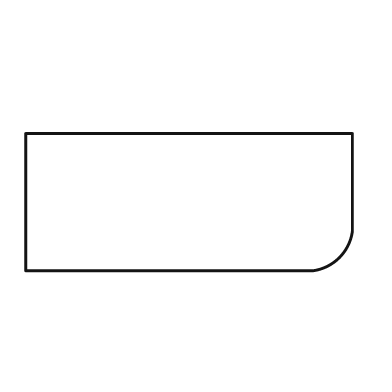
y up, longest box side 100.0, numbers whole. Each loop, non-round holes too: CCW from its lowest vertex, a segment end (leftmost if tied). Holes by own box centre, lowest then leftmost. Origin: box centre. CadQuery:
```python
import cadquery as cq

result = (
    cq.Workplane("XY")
    .moveTo(-50.0, -21.0)
    .lineTo(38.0, -21.0)
    .threePointArc((46.0, -17.0), (50.0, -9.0))
    .lineTo(50.0, 21.0)
    .lineTo(-50.0, 21.0)
    .close()
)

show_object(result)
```